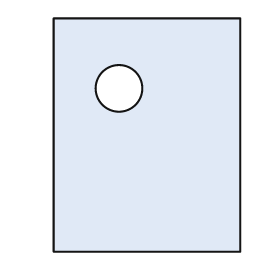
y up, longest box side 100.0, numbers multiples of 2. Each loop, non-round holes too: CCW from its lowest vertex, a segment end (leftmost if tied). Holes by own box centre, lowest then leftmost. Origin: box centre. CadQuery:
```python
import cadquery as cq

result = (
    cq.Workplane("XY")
    .moveTo(-40.0, -50.0)
    .lineTo(40.0, -50.0)
    .lineTo(40.0, 50.0)
    .lineTo(-40.0, 50.0)
    .close()
    .moveTo(-12.0, 20.0)
    .circle(10.0)
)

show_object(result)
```